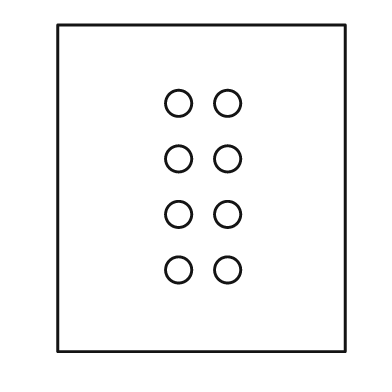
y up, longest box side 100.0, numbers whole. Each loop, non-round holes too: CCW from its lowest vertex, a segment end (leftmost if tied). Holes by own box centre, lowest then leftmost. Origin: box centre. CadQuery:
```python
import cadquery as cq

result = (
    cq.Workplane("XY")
    .moveTo(-44.0, -50.0)
    .lineTo(44.0, -50.0)
    .lineTo(44.0, 50.0)
    .lineTo(-44.0, 50.0)
    .close()
    .moveTo(-7.0, -25.0)
    .circle(4.0)
    .moveTo(8.0, -25.0)
    .circle(4.0)
    .moveTo(-7.0, -8.0)
    .circle(4.0)
    .moveTo(8.0, -8.0)
    .circle(4.0)
    .moveTo(-7.0, 9.0)
    .circle(4.0)
    .moveTo(8.0, 9.0)
    .circle(4.0)
    .moveTo(-7.0, 26.0)
    .circle(4.0)
    .moveTo(8.0, 26.0)
    .circle(4.0)
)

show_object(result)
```